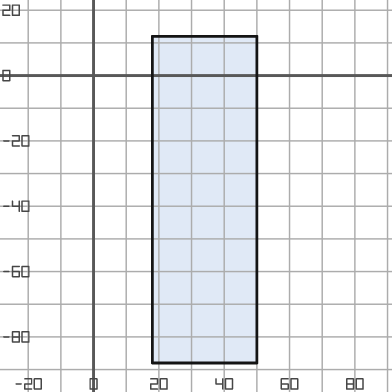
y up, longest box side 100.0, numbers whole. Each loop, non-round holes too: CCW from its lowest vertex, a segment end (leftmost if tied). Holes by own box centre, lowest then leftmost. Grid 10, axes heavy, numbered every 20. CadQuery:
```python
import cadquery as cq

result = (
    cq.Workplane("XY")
    .moveTo(18.0, -88.0)
    .lineTo(50.0, -88.0)
    .lineTo(50.0, 12.0)
    .lineTo(18.0, 12.0)
    .close()
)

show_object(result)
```